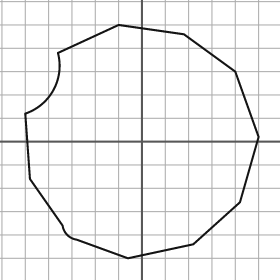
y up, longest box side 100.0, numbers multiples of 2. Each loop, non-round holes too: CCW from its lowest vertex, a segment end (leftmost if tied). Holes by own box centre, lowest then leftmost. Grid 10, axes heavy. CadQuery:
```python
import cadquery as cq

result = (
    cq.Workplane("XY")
    .moveTo(-6.0, -50.0)
    .lineTo(22.0, -44.0)
    .lineTo(42.0, -26.0)
    .lineTo(50.0, 2.0)
    .lineTo(40.0, 30.0)
    .lineTo(18.0, 46.0)
    .lineTo(-10.0, 50.0)
    .lineTo(-36.0, 38.0)
    .threePointArc((-38.0, 22.0), (-50.0, 12.0))
    .lineTo(-48.0, -16.0)
    .lineTo(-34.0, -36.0)
    .threePointArc((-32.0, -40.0), (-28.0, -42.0))
    .close()
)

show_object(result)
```